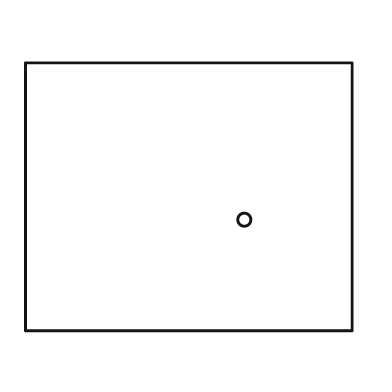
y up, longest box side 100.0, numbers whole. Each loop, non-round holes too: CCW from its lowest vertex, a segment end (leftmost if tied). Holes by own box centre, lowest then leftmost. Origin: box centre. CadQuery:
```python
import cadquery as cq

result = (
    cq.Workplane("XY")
    .moveTo(-50.0, -41.0)
    .lineTo(50.0, -41.0)
    .lineTo(50.0, 41.0)
    .lineTo(-50.0, 41.0)
    .close()
    .moveTo(17.0, -7.0)
    .circle(2.0)
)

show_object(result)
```